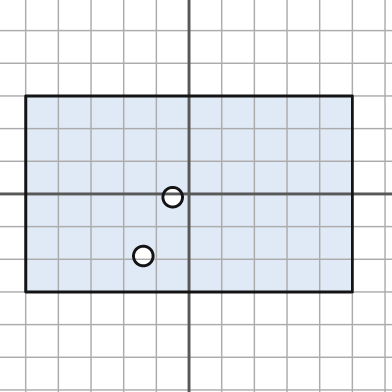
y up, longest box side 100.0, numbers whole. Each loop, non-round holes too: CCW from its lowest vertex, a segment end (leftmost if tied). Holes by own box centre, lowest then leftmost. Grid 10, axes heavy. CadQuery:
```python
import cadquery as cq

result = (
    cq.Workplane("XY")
    .moveTo(-50.0, -30.0)
    .lineTo(50.0, -30.0)
    .lineTo(50.0, 30.0)
    .lineTo(-50.0, 30.0)
    .close()
    .moveTo(-14.0, -19.0)
    .circle(3.0)
    .moveTo(-5.0, -1.0)
    .circle(3.0)
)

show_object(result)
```